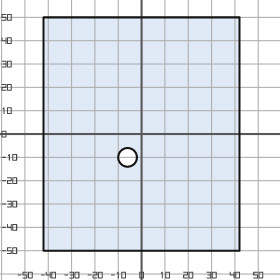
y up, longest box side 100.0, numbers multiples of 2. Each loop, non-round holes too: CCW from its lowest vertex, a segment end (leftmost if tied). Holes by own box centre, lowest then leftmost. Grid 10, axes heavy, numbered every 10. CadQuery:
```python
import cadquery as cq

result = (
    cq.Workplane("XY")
    .moveTo(-42.0, -50.0)
    .lineTo(42.0, -50.0)
    .lineTo(42.0, 50.0)
    .lineTo(-42.0, 50.0)
    .close()
    .moveTo(-6.0, -10.0)
    .circle(4.0)
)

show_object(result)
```